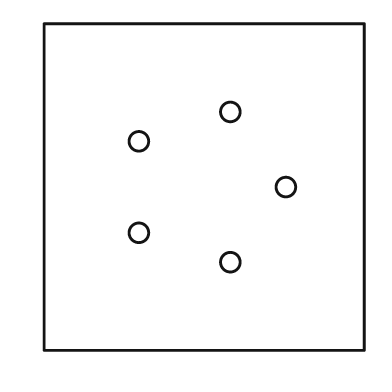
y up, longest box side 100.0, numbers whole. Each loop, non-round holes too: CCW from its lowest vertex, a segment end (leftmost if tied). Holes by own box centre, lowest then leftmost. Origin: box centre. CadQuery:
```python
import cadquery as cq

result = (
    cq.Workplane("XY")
    .moveTo(-49.0, -50.0)
    .lineTo(49.0, -50.0)
    .lineTo(49.0, 50.0)
    .lineTo(-49.0, 50.0)
    .close()
    .moveTo(8.0, -23.0)
    .circle(3.0)
    .moveTo(-20.0, -14.0)
    .circle(3.0)
    .moveTo(25.0, 0.0)
    .circle(3.0)
    .moveTo(-20.0, 14.0)
    .circle(3.0)
    .moveTo(8.0, 23.0)
    .circle(3.0)
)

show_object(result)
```